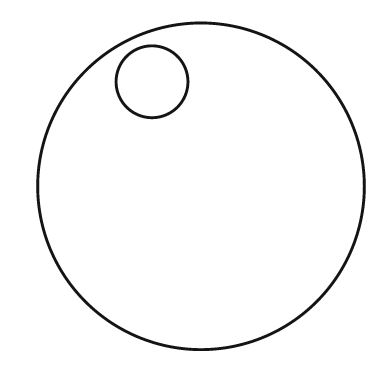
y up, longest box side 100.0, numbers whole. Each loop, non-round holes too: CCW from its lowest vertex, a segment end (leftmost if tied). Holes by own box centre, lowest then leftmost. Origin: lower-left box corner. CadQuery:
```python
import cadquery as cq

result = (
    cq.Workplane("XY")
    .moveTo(50.0, 50.0)
    .circle(50.0)
    .moveTo(35.0, 82.0)
    .circle(11.0)
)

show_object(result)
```